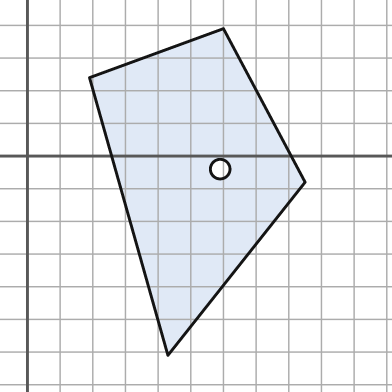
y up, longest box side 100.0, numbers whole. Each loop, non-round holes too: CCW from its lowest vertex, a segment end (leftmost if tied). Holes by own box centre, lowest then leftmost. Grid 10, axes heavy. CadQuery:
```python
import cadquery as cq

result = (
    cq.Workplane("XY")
    .moveTo(43.0, -61.0)
    .lineTo(85.0, -8.0)
    .lineTo(60.0, 39.0)
    .lineTo(19.0, 24.0)
    .close()
    .moveTo(59.0, -4.0)
    .circle(3.0)
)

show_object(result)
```